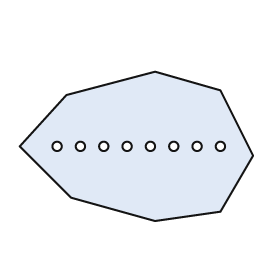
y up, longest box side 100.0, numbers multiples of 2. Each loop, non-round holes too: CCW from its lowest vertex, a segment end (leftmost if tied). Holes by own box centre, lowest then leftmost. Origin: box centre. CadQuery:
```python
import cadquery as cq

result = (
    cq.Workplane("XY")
    .moveTo(8.0, -32.0)
    .lineTo(36.0, -28.0)
    .lineTo(50.0, -4.0)
    .lineTo(36.0, 24.0)
    .lineTo(8.0, 32.0)
    .lineTo(-30.0, 22.0)
    .lineTo(-50.0, 0.0)
    .lineTo(-28.0, -22.0)
    .close()
    .moveTo(-34.0, 0.0)
    .circle(2.0)
    .moveTo(-24.0, 0.0)
    .circle(2.0)
    .moveTo(-14.0, 0.0)
    .circle(2.0)
    .moveTo(-4.0, 0.0)
    .circle(2.0)
    .moveTo(6.0, 0.0)
    .circle(2.0)
    .moveTo(16.0, 0.0)
    .circle(2.0)
    .moveTo(26.0, 0.0)
    .circle(2.0)
    .moveTo(36.0, 0.0)
    .circle(2.0)
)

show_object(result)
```